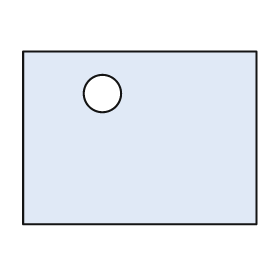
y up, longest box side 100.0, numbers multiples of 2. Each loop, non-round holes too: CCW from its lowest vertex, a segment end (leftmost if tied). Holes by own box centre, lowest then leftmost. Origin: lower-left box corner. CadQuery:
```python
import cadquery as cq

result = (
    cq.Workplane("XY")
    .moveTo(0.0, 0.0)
    .lineTo(100.0, 0.0)
    .lineTo(100.0, 74.0)
    .lineTo(0.0, 74.0)
    .close()
    .moveTo(34.0, 56.0)
    .circle(8.0)
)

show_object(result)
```